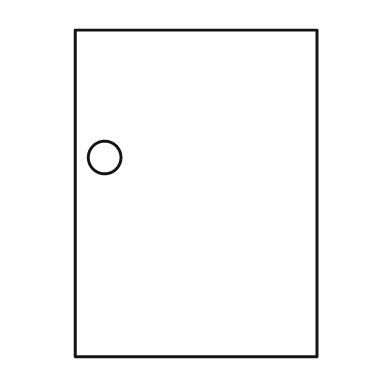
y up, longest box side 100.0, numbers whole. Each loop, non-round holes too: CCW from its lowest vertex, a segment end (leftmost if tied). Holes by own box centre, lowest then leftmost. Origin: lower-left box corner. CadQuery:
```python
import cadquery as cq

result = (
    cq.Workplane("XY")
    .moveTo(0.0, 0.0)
    .lineTo(74.0, 0.0)
    .lineTo(74.0, 100.0)
    .lineTo(0.0, 100.0)
    .close()
    .moveTo(9.0, 61.0)
    .circle(5.0)
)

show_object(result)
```